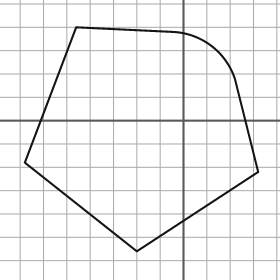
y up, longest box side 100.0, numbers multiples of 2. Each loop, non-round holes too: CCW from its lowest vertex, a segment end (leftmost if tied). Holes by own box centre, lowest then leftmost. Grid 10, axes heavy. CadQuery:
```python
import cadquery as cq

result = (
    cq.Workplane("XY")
    .moveTo(-20.0, -56.0)
    .lineTo(32.0, -22.0)
    .lineTo(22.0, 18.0)
    .threePointArc((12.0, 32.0), (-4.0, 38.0))
    .lineTo(-46.0, 40.0)
    .lineTo(-68.0, -18.0)
    .close()
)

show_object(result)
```